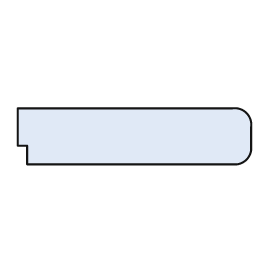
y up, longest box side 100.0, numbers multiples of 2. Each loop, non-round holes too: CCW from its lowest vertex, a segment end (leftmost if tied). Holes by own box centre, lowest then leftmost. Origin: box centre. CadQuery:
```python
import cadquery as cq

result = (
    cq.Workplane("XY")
    .moveTo(-46.0, -12.0)
    .lineTo(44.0, -12.0)
    .threePointArc((48.0, -10.0), (50.0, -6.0))
    .lineTo(50.0, 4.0)
    .threePointArc((48.0, 10.0), (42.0, 12.0))
    .lineTo(-50.0, 12.0)
    .lineTo(-50.0, -4.0)
    .lineTo(-46.0, -4.0)
    .close()
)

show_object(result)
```